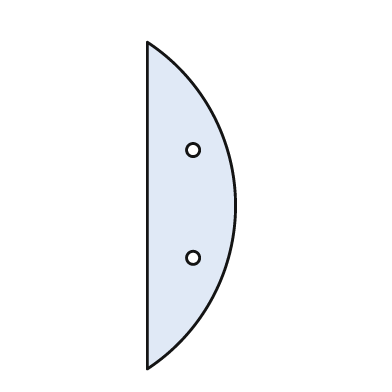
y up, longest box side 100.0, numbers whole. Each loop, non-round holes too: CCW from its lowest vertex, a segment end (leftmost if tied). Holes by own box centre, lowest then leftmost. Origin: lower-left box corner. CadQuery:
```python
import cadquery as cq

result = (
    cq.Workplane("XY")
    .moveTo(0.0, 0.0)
    .threePointArc((27.0, 50.0), (0.0, 100.0))
    .close()
    .moveTo(14.0, 34.0)
    .circle(2.0)
    .moveTo(14.0, 67.0)
    .circle(2.0)
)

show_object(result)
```